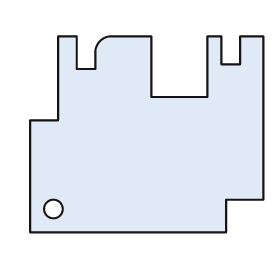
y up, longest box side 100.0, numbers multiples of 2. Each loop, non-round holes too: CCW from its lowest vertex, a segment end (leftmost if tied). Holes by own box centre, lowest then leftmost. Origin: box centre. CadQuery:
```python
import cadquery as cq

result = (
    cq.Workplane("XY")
    .moveTo(-50.0, -42.0)
    .lineTo(34.0, -42.0)
    .lineTo(34.0, -28.0)
    .lineTo(50.0, -28.0)
    .lineTo(50.0, 42.0)
    .lineTo(40.0, 42.0)
    .lineTo(40.0, 30.0)
    .lineTo(32.0, 30.0)
    .lineTo(32.0, 42.0)
    .lineTo(26.0, 42.0)
    .lineTo(26.0, 16.0)
    .lineTo(2.0, 16.0)
    .lineTo(2.0, 42.0)
    .lineTo(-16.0, 42.0)
    .threePointArc((-20.0, 40.0), (-22.0, 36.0))
    .lineTo(-22.0, 28.0)
    .lineTo(-30.0, 28.0)
    .lineTo(-30.0, 42.0)
    .lineTo(-38.0, 42.0)
    .lineTo(-38.0, 6.0)
    .lineTo(-50.0, 6.0)
    .close()
    .moveTo(-40.0, -32.0)
    .circle(4.0)
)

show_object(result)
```